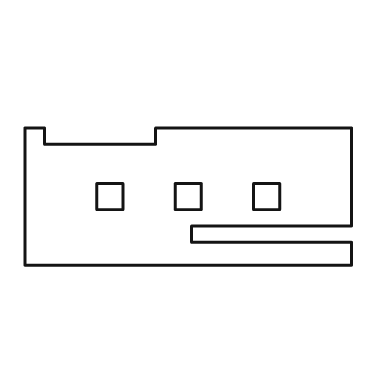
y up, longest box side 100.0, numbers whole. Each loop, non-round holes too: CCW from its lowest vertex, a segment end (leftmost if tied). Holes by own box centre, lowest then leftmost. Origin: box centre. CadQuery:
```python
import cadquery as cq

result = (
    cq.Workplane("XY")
    .moveTo(-50.0, -21.0)
    .lineTo(50.0, -21.0)
    .lineTo(50.0, -14.0)
    .lineTo(1.0, -14.0)
    .lineTo(1.0, -9.0)
    .lineTo(50.0, -9.0)
    .lineTo(50.0, 21.0)
    .lineTo(-10.0, 21.0)
    .lineTo(-10.0, 16.0)
    .lineTo(-44.0, 16.0)
    .lineTo(-44.0, 21.0)
    .lineTo(-50.0, 21.0)
    .close()
    .moveTo(-28.0, -4.0)
    .lineTo(-20.0, -4.0)
    .lineTo(-20.0, 4.0)
    .lineTo(-28.0, 4.0)
    .close()
    .moveTo(-4.0, -4.0)
    .lineTo(4.0, -4.0)
    .lineTo(4.0, 4.0)
    .lineTo(-4.0, 4.0)
    .close()
    .moveTo(20.0, -4.0)
    .lineTo(28.0, -4.0)
    .lineTo(28.0, 4.0)
    .lineTo(20.0, 4.0)
    .close()
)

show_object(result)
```